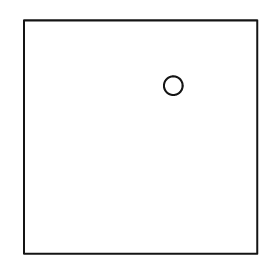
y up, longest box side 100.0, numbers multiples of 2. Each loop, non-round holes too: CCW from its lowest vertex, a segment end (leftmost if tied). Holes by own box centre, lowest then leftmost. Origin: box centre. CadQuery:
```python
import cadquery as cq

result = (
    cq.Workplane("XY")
    .moveTo(-50.0, -50.0)
    .lineTo(50.0, -50.0)
    .lineTo(50.0, 50.0)
    .lineTo(-50.0, 50.0)
    .close()
    .moveTo(14.0, 22.0)
    .circle(4.0)
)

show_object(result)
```